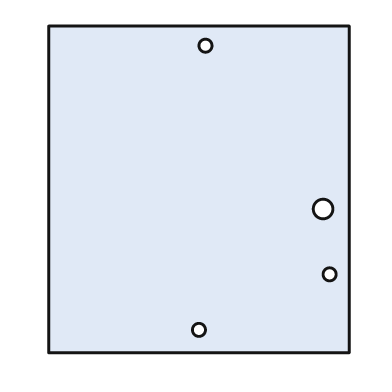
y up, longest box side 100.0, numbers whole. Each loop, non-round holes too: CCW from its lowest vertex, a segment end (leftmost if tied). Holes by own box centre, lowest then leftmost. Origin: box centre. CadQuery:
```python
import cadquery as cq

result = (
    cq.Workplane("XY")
    .moveTo(-46.0, -50.0)
    .lineTo(46.0, -50.0)
    .lineTo(46.0, 50.0)
    .lineTo(-46.0, 50.0)
    .close()
    .moveTo(0.0, -43.0)
    .circle(2.0)
    .moveTo(40.0, -26.0)
    .circle(2.0)
    .moveTo(38.0, -6.0)
    .circle(3.0)
    .moveTo(2.0, 44.0)
    .circle(2.0)
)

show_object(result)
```